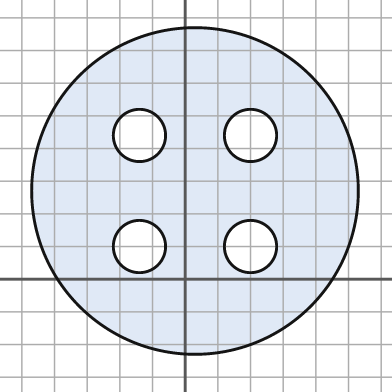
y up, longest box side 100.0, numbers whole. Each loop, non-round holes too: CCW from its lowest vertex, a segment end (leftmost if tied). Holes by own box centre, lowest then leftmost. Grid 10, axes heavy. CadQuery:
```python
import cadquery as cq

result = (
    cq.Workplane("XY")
    .moveTo(3.0, 27.0)
    .circle(50.0)
    .moveTo(-14.0, 10.0)
    .circle(8.0)
    .moveTo(20.0, 10.0)
    .circle(8.0)
    .moveTo(-14.0, 44.0)
    .circle(8.0)
    .moveTo(20.0, 44.0)
    .circle(8.0)
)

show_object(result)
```